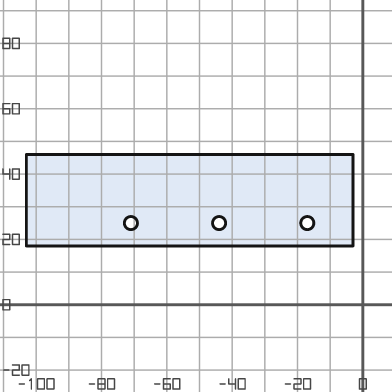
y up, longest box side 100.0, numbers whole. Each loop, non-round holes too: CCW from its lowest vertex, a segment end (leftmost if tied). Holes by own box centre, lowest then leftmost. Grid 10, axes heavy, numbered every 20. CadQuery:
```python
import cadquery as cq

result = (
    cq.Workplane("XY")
    .moveTo(-103.0, 18.0)
    .lineTo(-3.0, 18.0)
    .lineTo(-3.0, 46.0)
    .lineTo(-103.0, 46.0)
    .close()
    .moveTo(-71.0, 25.0)
    .circle(2.0)
    .moveTo(-44.0, 25.0)
    .circle(2.0)
    .moveTo(-17.0, 25.0)
    .circle(2.0)
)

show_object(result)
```